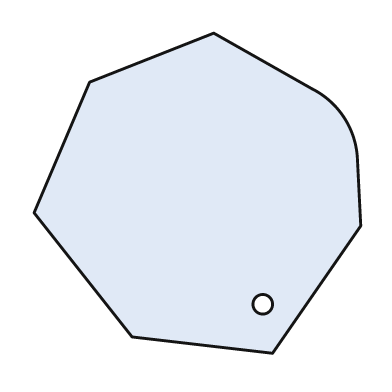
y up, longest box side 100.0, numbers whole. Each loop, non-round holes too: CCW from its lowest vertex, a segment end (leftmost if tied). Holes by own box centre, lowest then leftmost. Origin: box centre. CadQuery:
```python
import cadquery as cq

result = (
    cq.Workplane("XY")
    .moveTo(23.0, -49.0)
    .lineTo(50.0, -10.0)
    .lineTo(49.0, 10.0)
    .threePointArc((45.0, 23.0), (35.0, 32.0))
    .lineTo(5.0, 49.0)
    .lineTo(-33.0, 34.0)
    .lineTo(-50.0, -6.0)
    .lineTo(-20.0, -44.0)
    .close()
    .moveTo(20.0, -34.0)
    .circle(3.0)
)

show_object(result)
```